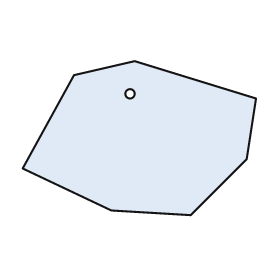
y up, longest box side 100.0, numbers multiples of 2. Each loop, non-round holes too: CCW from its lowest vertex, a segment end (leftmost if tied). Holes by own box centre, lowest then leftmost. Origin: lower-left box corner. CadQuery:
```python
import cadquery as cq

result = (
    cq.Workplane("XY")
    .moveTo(72.0, 0.0)
    .lineTo(96.0, 24.0)
    .lineTo(100.0, 50.0)
    .lineTo(48.0, 66.0)
    .lineTo(22.0, 60.0)
    .lineTo(0.0, 20.0)
    .lineTo(38.0, 2.0)
    .close()
    .moveTo(46.0, 52.0)
    .circle(2.0)
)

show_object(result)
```